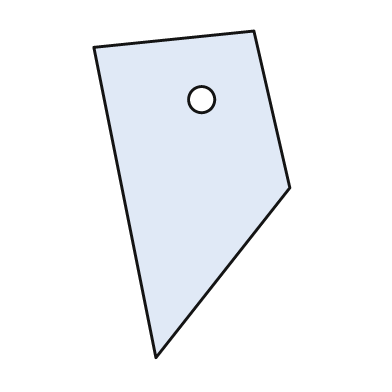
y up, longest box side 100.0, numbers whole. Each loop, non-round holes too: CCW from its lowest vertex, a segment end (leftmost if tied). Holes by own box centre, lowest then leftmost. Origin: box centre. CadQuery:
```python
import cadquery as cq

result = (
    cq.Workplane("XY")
    .moveTo(-11.0, -50.0)
    .lineTo(30.0, 2.0)
    .lineTo(19.0, 50.0)
    .lineTo(-30.0, 45.0)
    .close()
    .moveTo(3.0, 29.0)
    .circle(4.0)
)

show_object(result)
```